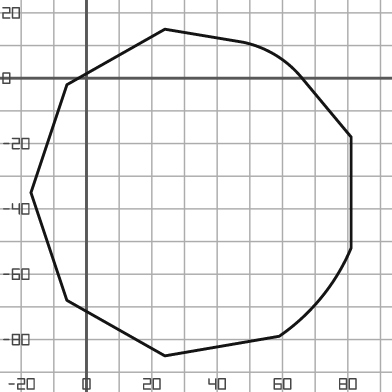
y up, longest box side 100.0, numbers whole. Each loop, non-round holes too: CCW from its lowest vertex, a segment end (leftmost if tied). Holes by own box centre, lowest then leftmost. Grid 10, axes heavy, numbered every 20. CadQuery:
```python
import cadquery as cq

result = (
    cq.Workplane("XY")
    .moveTo(24.0, -85.0)
    .lineTo(59.0, -79.0)
    .threePointArc((72.0, -67.0), (81.0, -52.0))
    .lineTo(81.0, -18.0)
    .lineTo(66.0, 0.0)
    .threePointArc((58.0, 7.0), (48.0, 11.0))
    .lineTo(24.0, 15.0)
    .lineTo(-6.0, -2.0)
    .lineTo(-17.0, -35.0)
    .lineTo(-6.0, -68.0)
    .close()
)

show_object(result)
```